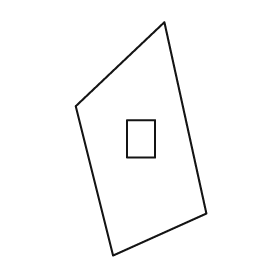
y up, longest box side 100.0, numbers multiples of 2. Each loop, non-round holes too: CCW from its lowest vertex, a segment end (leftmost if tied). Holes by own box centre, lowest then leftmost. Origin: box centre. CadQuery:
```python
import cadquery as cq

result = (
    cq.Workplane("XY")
    .moveTo(-12.0, -50.0)
    .lineTo(28.0, -32.0)
    .lineTo(10.0, 50.0)
    .lineTo(-28.0, 14.0)
    .close()
    .moveTo(-6.0, -8.0)
    .lineTo(6.0, -8.0)
    .lineTo(6.0, 8.0)
    .lineTo(-6.0, 8.0)
    .close()
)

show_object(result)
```